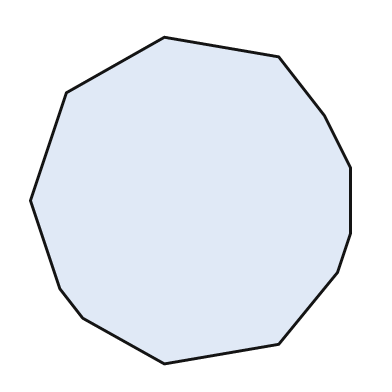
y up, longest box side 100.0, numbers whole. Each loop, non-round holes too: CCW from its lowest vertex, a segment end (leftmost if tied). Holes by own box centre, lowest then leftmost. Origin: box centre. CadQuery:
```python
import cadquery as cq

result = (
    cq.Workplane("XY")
    .moveTo(-8.0, -50.0)
    .lineTo(27.0, -44.0)
    .lineTo(45.0, -22.0)
    .lineTo(49.0, -10.0)
    .lineTo(49.0, 10.0)
    .lineTo(41.0, 26.0)
    .lineTo(27.0, 44.0)
    .lineTo(-8.0, 50.0)
    .lineTo(-38.0, 33.0)
    .lineTo(-49.0, 0.0)
    .lineTo(-40.0, -27.0)
    .lineTo(-33.0, -36.0)
    .close()
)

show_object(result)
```